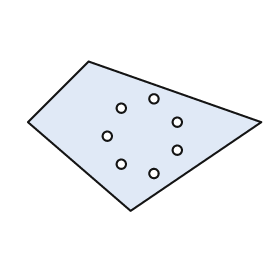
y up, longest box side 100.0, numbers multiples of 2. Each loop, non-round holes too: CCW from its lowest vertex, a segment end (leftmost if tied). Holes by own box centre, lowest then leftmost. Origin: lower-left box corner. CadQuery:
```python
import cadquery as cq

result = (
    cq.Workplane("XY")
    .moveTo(44.0, 0.0)
    .lineTo(100.0, 38.0)
    .lineTo(26.0, 64.0)
    .lineTo(0.0, 38.0)
    .close()
    .moveTo(54.0, 16.0)
    .circle(2.0)
    .moveTo(40.0, 20.0)
    .circle(2.0)
    .moveTo(64.0, 26.0)
    .circle(2.0)
    .moveTo(34.0, 32.0)
    .circle(2.0)
    .moveTo(64.0, 38.0)
    .circle(2.0)
    .moveTo(40.0, 44.0)
    .circle(2.0)
    .moveTo(54.0, 48.0)
    .circle(2.0)
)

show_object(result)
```